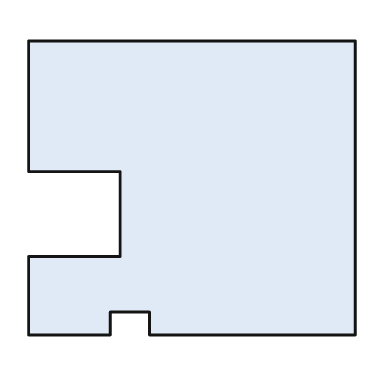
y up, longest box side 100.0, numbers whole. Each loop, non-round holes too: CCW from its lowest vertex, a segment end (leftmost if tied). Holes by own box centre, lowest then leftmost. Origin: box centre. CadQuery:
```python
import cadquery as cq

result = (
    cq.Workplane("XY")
    .moveTo(-50.0, -45.0)
    .lineTo(-25.0, -45.0)
    .lineTo(-25.0, -38.0)
    .lineTo(-13.0, -38.0)
    .lineTo(-13.0, -45.0)
    .lineTo(50.0, -45.0)
    .lineTo(50.0, 45.0)
    .lineTo(-50.0, 45.0)
    .lineTo(-50.0, 5.0)
    .lineTo(-22.0, 5.0)
    .lineTo(-22.0, -21.0)
    .lineTo(-50.0, -21.0)
    .close()
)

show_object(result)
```